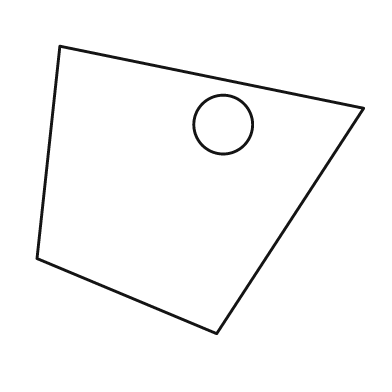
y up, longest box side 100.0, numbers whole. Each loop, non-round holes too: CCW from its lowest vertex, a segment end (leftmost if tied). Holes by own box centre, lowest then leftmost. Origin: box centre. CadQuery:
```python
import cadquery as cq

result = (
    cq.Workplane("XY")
    .moveTo(5.0, -44.0)
    .lineTo(50.0, 25.0)
    .lineTo(-43.0, 44.0)
    .lineTo(-50.0, -21.0)
    .close()
    .moveTo(7.0, 20.0)
    .circle(9.0)
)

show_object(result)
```